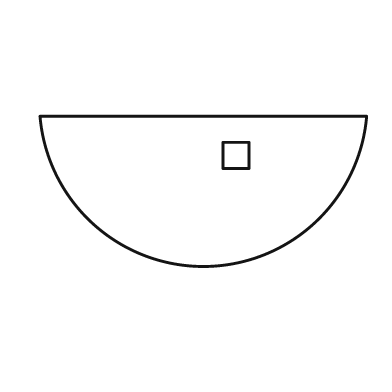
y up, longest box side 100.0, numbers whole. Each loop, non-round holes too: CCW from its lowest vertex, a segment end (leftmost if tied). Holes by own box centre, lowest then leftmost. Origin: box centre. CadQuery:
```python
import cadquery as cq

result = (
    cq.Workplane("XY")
    .moveTo(-50.0, 23.0)
    .threePointArc((0.0, -23.0), (50.0, 23.0))
    .close()
    .moveTo(6.0, 7.0)
    .lineTo(14.0, 7.0)
    .lineTo(14.0, 15.0)
    .lineTo(6.0, 15.0)
    .close()
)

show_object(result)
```